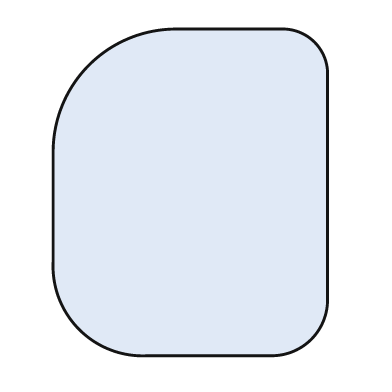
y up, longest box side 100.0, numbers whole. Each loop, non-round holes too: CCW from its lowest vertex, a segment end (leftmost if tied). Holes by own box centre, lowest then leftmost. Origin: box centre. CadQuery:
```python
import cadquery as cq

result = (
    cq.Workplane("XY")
    .moveTo(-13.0, -50.0)
    .lineTo(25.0, -50.0)
    .threePointArc((37.0, -45.0), (42.0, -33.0))
    .lineTo(42.0, 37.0)
    .threePointArc((38.0, 46.0), (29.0, 50.0))
    .lineTo(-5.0, 50.0)
    .threePointArc((-31.0, 39.0), (-42.0, 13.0))
    .lineTo(-42.0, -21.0)
    .threePointArc((-34.0, -42.0), (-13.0, -50.0))
    .close()
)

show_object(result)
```